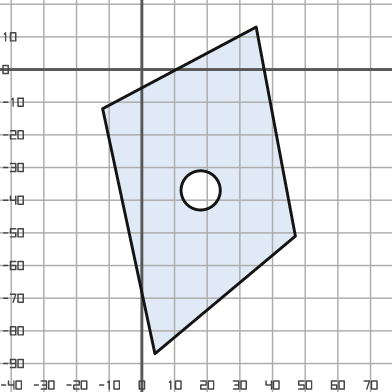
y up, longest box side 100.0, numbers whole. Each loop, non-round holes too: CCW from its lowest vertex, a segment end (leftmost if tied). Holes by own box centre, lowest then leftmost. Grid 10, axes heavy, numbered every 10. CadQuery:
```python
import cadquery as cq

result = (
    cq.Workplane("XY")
    .moveTo(4.0, -87.0)
    .lineTo(47.0, -51.0)
    .lineTo(35.0, 13.0)
    .lineTo(-12.0, -12.0)
    .close()
    .moveTo(18.0, -37.0)
    .circle(6.0)
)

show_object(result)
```